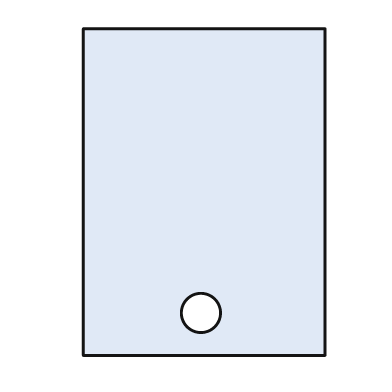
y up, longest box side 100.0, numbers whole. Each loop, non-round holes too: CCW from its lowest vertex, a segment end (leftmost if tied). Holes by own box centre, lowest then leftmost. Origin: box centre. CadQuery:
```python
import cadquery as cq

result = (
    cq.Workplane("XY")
    .moveTo(-37.0, -50.0)
    .lineTo(37.0, -50.0)
    .lineTo(37.0, 50.0)
    .lineTo(-37.0, 50.0)
    .close()
    .moveTo(-1.0, -37.0)
    .circle(6.0)
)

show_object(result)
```